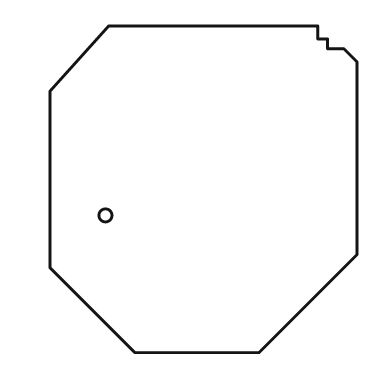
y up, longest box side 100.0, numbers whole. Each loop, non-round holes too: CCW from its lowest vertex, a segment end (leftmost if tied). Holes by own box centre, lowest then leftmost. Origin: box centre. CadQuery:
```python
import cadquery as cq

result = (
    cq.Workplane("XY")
    .moveTo(-21.0, -50.0)
    .lineTo(17.0, -50.0)
    .lineTo(47.0, -20.0)
    .lineTo(47.0, 39.0)
    .lineTo(43.0, 43.0)
    .lineTo(38.0, 43.0)
    .lineTo(38.0, 46.0)
    .lineTo(35.0, 46.0)
    .lineTo(35.0, 50.0)
    .lineTo(-29.0, 50.0)
    .lineTo(-47.0, 30.0)
    .lineTo(-47.0, -24.0)
    .close()
    .moveTo(-30.0, -8.0)
    .circle(2.0)
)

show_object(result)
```